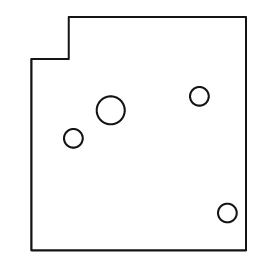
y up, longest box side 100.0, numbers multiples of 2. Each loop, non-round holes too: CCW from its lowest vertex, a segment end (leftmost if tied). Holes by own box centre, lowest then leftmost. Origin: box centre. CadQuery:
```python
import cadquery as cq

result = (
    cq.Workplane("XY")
    .moveTo(-46.0, -50.0)
    .lineTo(46.0, -50.0)
    .lineTo(46.0, 50.0)
    .lineTo(-30.0, 50.0)
    .lineTo(-30.0, 32.0)
    .lineTo(-46.0, 32.0)
    .close()
    .moveTo(38.0, -34.0)
    .circle(4.0)
    .moveTo(-28.0, -2.0)
    .circle(4.0)
    .moveTo(-12.0, 10.0)
    .circle(6.0)
    .moveTo(26.0, 16.0)
    .circle(4.0)
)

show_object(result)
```